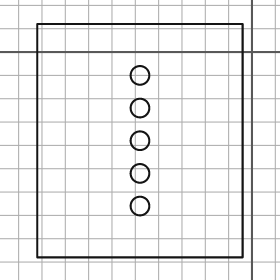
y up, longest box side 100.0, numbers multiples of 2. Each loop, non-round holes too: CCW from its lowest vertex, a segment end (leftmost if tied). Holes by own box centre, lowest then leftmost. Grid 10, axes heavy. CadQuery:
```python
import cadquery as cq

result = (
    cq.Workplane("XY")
    .moveTo(-92.0, -88.0)
    .lineTo(-4.0, -88.0)
    .lineTo(-4.0, 12.0)
    .lineTo(-92.0, 12.0)
    .close()
    .moveTo(-48.0, -66.0)
    .circle(4.0)
    .moveTo(-48.0, -52.0)
    .circle(4.0)
    .moveTo(-48.0, -38.0)
    .circle(4.0)
    .moveTo(-48.0, -24.0)
    .circle(4.0)
    .moveTo(-48.0, -10.0)
    .circle(4.0)
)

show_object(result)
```